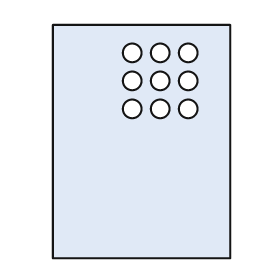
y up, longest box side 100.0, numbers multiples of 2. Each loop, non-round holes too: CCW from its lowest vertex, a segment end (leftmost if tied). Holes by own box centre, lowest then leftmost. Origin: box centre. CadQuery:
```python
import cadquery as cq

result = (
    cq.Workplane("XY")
    .moveTo(-38.0, -50.0)
    .lineTo(38.0, -50.0)
    .lineTo(38.0, 50.0)
    .lineTo(-38.0, 50.0)
    .close()
    .moveTo(-4.0, 14.0)
    .circle(4.0)
    .moveTo(8.0, 14.0)
    .circle(4.0)
    .moveTo(20.0, 14.0)
    .circle(4.0)
    .moveTo(-4.0, 26.0)
    .circle(4.0)
    .moveTo(8.0, 26.0)
    .circle(4.0)
    .moveTo(20.0, 26.0)
    .circle(4.0)
    .moveTo(-4.0, 38.0)
    .circle(4.0)
    .moveTo(8.0, 38.0)
    .circle(4.0)
    .moveTo(20.0, 38.0)
    .circle(4.0)
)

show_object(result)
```